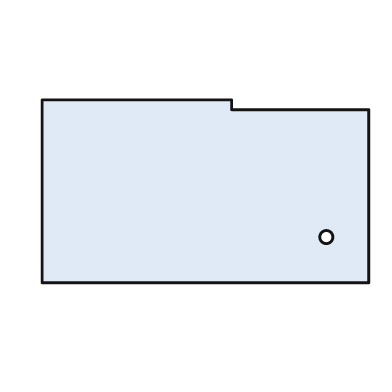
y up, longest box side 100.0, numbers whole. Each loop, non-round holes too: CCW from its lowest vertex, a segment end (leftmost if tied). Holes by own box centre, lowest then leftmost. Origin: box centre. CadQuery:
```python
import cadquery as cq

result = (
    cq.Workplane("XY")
    .moveTo(-50.0, -28.0)
    .lineTo(50.0, -28.0)
    .lineTo(50.0, 25.0)
    .lineTo(8.0, 25.0)
    .lineTo(8.0, 28.0)
    .lineTo(-50.0, 28.0)
    .close()
    .moveTo(37.0, -14.0)
    .circle(2.0)
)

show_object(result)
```